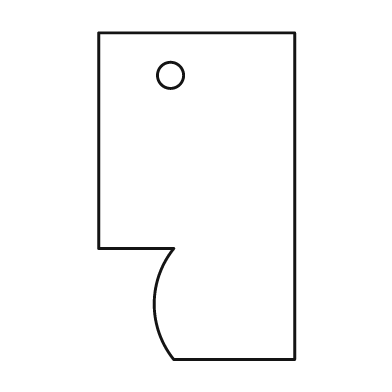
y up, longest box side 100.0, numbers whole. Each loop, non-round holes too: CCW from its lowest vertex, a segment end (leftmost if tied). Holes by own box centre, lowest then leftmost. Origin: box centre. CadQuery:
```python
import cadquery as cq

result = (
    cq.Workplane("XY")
    .moveTo(-7.0, -50.0)
    .lineTo(30.0, -50.0)
    .lineTo(30.0, 50.0)
    .lineTo(-30.0, 50.0)
    .lineTo(-30.0, -16.0)
    .lineTo(-7.0, -16.0)
    .threePointArc((-13.0, -33.0), (-7.0, -50.0))
    .close()
    .moveTo(-8.0, 37.0)
    .circle(4.0)
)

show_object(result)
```